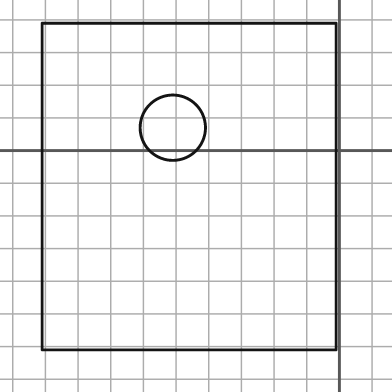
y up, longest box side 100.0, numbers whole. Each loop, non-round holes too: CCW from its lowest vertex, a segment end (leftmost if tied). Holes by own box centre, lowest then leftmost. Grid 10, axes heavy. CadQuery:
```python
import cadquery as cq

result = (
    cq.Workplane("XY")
    .moveTo(-91.0, -61.0)
    .lineTo(-1.0, -61.0)
    .lineTo(-1.0, 39.0)
    .lineTo(-91.0, 39.0)
    .close()
    .moveTo(-51.0, 7.0)
    .circle(10.0)
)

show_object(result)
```